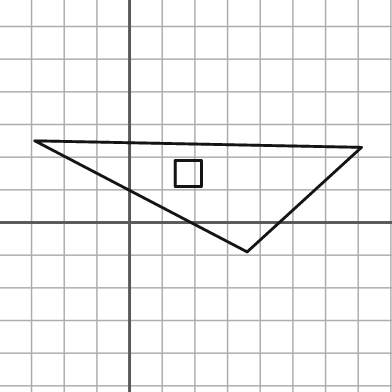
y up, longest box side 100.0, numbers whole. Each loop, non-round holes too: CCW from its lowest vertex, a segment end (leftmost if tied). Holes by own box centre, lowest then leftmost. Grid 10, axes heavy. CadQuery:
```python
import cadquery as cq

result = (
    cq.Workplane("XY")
    .moveTo(36.0, -9.0)
    .lineTo(71.0, 23.0)
    .lineTo(-29.0, 25.0)
    .close()
    .moveTo(14.0, 11.0)
    .lineTo(22.0, 11.0)
    .lineTo(22.0, 19.0)
    .lineTo(14.0, 19.0)
    .close()
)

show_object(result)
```